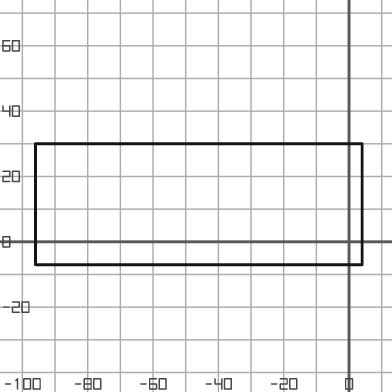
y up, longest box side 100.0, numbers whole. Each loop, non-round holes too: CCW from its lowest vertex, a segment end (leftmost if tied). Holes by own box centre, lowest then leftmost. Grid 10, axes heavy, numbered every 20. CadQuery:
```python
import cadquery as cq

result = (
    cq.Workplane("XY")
    .moveTo(-96.0, -7.0)
    .lineTo(4.0, -7.0)
    .lineTo(4.0, 30.0)
    .lineTo(-96.0, 30.0)
    .close()
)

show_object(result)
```